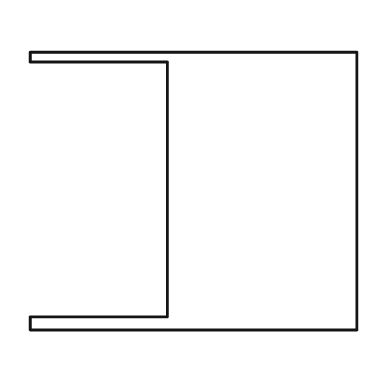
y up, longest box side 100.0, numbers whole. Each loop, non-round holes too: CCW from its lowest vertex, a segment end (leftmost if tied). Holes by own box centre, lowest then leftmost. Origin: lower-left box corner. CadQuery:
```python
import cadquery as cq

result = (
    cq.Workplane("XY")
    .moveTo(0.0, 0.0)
    .lineTo(100.0, 0.0)
    .lineTo(100.0, 85.0)
    .lineTo(0.0, 85.0)
    .lineTo(0.0, 82.0)
    .lineTo(42.0, 82.0)
    .lineTo(42.0, 4.0)
    .lineTo(0.0, 4.0)
    .close()
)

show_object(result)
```